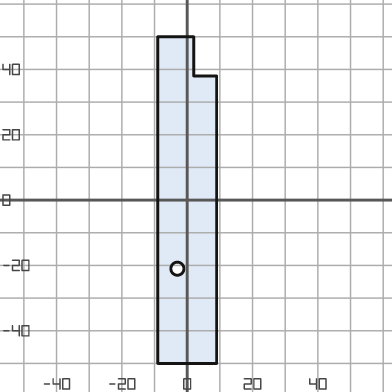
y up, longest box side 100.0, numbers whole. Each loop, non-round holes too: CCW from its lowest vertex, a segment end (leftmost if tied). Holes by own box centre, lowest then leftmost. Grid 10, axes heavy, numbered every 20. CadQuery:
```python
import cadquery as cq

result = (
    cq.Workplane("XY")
    .moveTo(-9.0, -50.0)
    .lineTo(9.0, -50.0)
    .lineTo(9.0, 38.0)
    .lineTo(2.0, 38.0)
    .lineTo(2.0, 50.0)
    .lineTo(-9.0, 50.0)
    .close()
    .moveTo(-3.0, -21.0)
    .circle(2.0)
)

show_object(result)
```